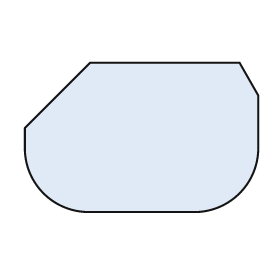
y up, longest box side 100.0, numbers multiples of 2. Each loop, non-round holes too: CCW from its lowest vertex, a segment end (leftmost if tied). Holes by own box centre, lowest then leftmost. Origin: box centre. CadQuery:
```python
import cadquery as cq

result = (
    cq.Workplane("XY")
    .moveTo(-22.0, -32.0)
    .lineTo(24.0, -32.0)
    .threePointArc((42.0, -24.0), (50.0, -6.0))
    .lineTo(50.0, 18.0)
    .lineTo(42.0, 32.0)
    .lineTo(-22.0, 32.0)
    .lineTo(-50.0, 4.0)
    .lineTo(-50.0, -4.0)
    .threePointArc((-42.0, -24.0), (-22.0, -32.0))
    .close()
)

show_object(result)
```